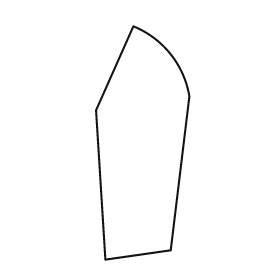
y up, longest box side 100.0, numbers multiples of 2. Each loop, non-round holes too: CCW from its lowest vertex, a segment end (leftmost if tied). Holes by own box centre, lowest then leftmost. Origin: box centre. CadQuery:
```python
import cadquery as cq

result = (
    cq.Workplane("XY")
    .moveTo(-16.0, -50.0)
    .lineTo(12.0, -46.0)
    .lineTo(20.0, 20.0)
    .threePointArc((12.0, 38.0), (-4.0, 50.0))
    .lineTo(-20.0, 14.0)
    .close()
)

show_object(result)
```